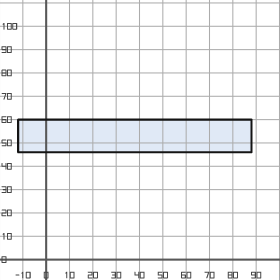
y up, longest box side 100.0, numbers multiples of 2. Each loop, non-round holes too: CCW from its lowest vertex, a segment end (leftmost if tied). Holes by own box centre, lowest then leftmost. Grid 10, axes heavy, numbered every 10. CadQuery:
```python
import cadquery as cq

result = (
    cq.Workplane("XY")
    .moveTo(-12.0, 46.0)
    .lineTo(88.0, 46.0)
    .lineTo(88.0, 60.0)
    .lineTo(-12.0, 60.0)
    .close()
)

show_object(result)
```